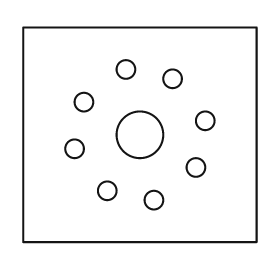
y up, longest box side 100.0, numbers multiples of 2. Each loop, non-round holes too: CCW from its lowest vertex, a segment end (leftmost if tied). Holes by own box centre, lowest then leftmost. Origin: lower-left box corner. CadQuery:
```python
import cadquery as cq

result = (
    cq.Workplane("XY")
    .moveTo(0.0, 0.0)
    .lineTo(100.0, 0.0)
    .lineTo(100.0, 92.0)
    .lineTo(0.0, 92.0)
    .close()
    .moveTo(56.0, 18.0)
    .circle(4.0)
    .moveTo(36.0, 22.0)
    .circle(4.0)
    .moveTo(74.0, 32.0)
    .circle(4.0)
    .moveTo(22.0, 40.0)
    .circle(4.0)
    .moveTo(50.0, 46.0)
    .circle(10.0)
    .moveTo(78.0, 52.0)
    .circle(4.0)
    .moveTo(26.0, 60.0)
    .circle(4.0)
    .moveTo(64.0, 70.0)
    .circle(4.0)
    .moveTo(44.0, 74.0)
    .circle(4.0)
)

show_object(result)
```